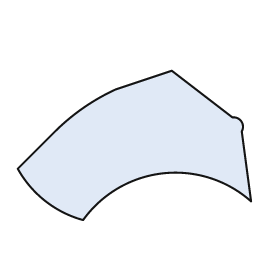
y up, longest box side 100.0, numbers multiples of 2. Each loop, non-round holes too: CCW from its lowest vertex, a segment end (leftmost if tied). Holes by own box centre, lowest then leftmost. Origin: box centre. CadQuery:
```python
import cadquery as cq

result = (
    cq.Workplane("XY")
    .moveTo(-22.0, -32.0)
    .threePointArc((12.0, -12.0), (50.0, -24.0))
    .lineTo(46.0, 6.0)
    .threePointArc((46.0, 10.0), (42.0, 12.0))
    .lineTo(16.0, 32.0)
    .lineTo(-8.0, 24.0)
    .threePointArc((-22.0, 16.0), (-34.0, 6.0))
    .lineTo(-50.0, -10.0)
    .threePointArc((-38.0, -24.0), (-22.0, -32.0))
    .close()
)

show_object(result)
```